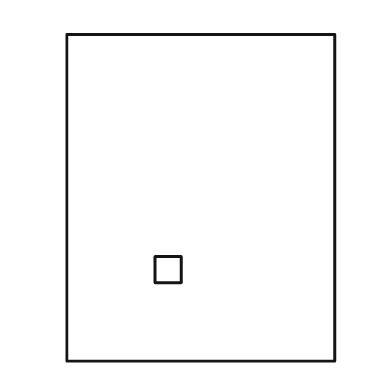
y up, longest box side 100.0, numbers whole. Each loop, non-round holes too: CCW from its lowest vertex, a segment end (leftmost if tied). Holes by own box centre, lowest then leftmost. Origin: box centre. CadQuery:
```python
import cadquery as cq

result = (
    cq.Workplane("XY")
    .moveTo(-41.0, -50.0)
    .lineTo(41.0, -50.0)
    .lineTo(41.0, 50.0)
    .lineTo(-41.0, 50.0)
    .close()
    .moveTo(-14.0, -26.0)
    .lineTo(-6.0, -26.0)
    .lineTo(-6.0, -18.0)
    .lineTo(-14.0, -18.0)
    .close()
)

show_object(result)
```